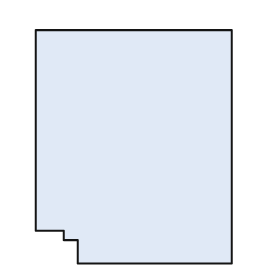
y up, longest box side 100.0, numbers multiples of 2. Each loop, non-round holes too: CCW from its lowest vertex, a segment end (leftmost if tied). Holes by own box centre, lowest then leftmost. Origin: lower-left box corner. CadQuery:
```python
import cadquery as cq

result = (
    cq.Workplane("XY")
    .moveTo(18.0, 0.0)
    .lineTo(84.0, 0.0)
    .lineTo(84.0, 100.0)
    .lineTo(0.0, 100.0)
    .lineTo(0.0, 14.0)
    .lineTo(12.0, 14.0)
    .lineTo(12.0, 10.0)
    .lineTo(18.0, 10.0)
    .close()
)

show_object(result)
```